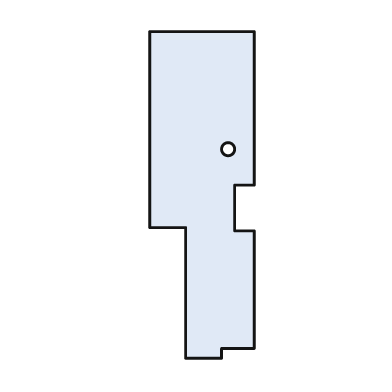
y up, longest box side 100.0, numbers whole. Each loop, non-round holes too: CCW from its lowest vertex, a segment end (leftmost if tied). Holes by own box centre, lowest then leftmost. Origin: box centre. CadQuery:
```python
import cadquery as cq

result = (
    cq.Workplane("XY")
    .moveTo(-5.0, -50.0)
    .lineTo(6.0, -50.0)
    .lineTo(6.0, -47.0)
    .lineTo(16.0, -47.0)
    .lineTo(16.0, -11.0)
    .lineTo(10.0, -11.0)
    .lineTo(10.0, 3.0)
    .lineTo(16.0, 3.0)
    .lineTo(16.0, 50.0)
    .lineTo(-16.0, 50.0)
    .lineTo(-16.0, -10.0)
    .lineTo(-5.0, -10.0)
    .close()
    .moveTo(8.0, 14.0)
    .circle(2.0)
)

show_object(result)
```